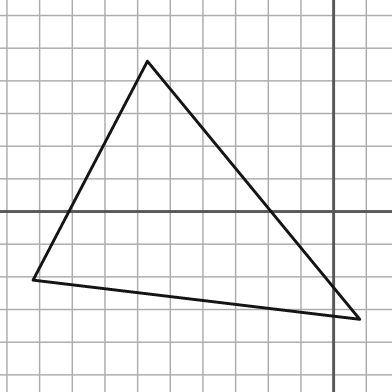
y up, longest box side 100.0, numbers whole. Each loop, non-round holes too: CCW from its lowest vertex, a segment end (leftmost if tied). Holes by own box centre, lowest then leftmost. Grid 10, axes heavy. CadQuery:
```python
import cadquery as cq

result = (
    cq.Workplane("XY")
    .moveTo(8.0, -33.0)
    .lineTo(-57.0, 46.0)
    .lineTo(-92.0, -21.0)
    .close()
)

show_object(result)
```